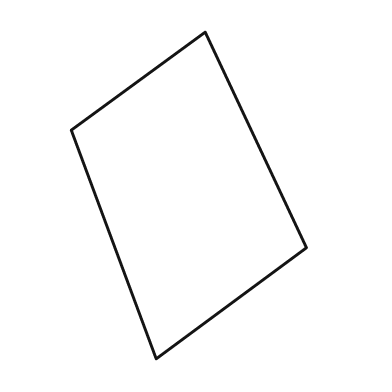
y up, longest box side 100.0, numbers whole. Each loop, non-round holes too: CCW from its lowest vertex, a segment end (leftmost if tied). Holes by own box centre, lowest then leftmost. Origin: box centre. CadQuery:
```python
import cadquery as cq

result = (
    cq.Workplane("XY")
    .moveTo(-10.0, -50.0)
    .lineTo(36.0, -16.0)
    .lineTo(5.0, 50.0)
    .lineTo(-36.0, 20.0)
    .close()
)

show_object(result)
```